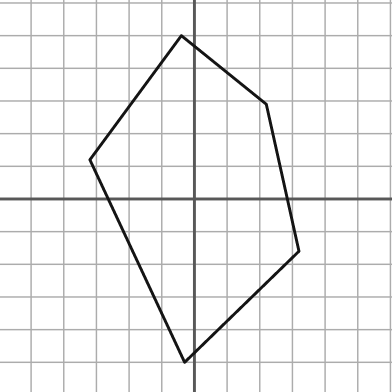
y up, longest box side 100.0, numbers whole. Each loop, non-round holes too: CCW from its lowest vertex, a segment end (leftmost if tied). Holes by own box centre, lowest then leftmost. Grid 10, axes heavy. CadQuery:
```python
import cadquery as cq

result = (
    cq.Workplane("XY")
    .moveTo(-3.0, -50.0)
    .lineTo(32.0, -16.0)
    .lineTo(22.0, 29.0)
    .lineTo(-4.0, 50.0)
    .lineTo(-32.0, 12.0)
    .close()
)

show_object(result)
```